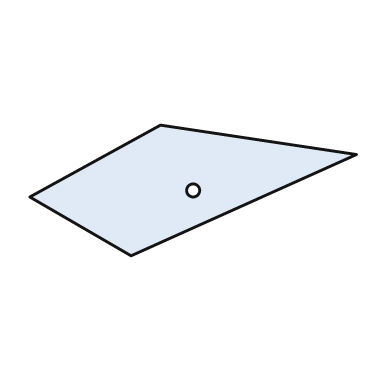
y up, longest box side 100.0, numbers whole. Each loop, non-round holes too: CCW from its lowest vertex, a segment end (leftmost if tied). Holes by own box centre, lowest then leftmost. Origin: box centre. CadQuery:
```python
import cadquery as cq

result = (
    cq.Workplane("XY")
    .moveTo(-19.0, -20.0)
    .lineTo(50.0, 11.0)
    .lineTo(-10.0, 20.0)
    .lineTo(-50.0, -2.0)
    .close()
    .moveTo(0.0, 0.0)
    .circle(2.0)
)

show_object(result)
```